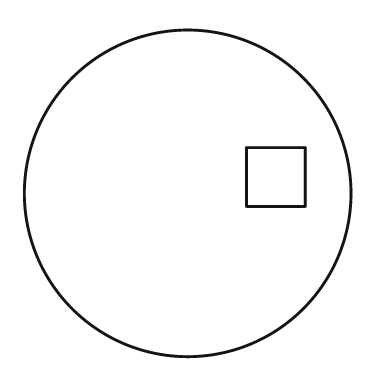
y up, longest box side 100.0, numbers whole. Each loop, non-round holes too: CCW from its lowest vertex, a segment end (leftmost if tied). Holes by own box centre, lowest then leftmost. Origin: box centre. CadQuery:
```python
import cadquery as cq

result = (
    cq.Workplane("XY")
    .moveTo(0.0, 0.0)
    .circle(50.0)
    .moveTo(18.0, -4.0)
    .lineTo(36.0, -4.0)
    .lineTo(36.0, 14.0)
    .lineTo(18.0, 14.0)
    .close()
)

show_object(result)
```